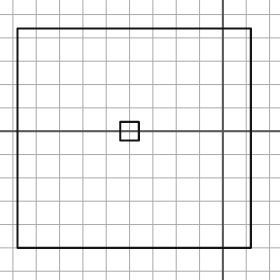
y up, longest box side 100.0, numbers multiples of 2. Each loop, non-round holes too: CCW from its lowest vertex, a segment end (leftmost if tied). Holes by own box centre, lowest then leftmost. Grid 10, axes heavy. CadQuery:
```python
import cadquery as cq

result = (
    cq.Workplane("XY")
    .moveTo(-88.0, -50.0)
    .lineTo(12.0, -50.0)
    .lineTo(12.0, 44.0)
    .lineTo(-88.0, 44.0)
    .close()
    .moveTo(-44.0, -4.0)
    .lineTo(-36.0, -4.0)
    .lineTo(-36.0, 4.0)
    .lineTo(-44.0, 4.0)
    .close()
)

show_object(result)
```